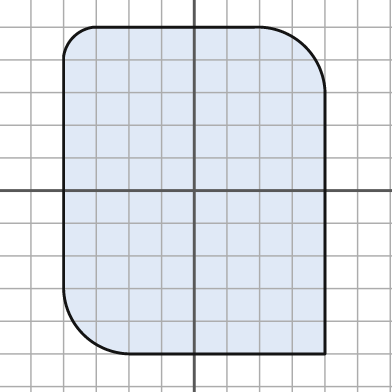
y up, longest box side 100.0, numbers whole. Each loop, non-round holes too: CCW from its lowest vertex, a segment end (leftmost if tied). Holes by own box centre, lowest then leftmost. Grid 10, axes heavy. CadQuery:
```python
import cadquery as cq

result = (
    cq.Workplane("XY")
    .moveTo(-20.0, -50.0)
    .lineTo(40.0, -50.0)
    .lineTo(40.0, 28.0)
    .threePointArc((34.0, 44.0), (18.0, 50.0))
    .lineTo(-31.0, 50.0)
    .threePointArc((-37.0, 47.0), (-40.0, 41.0))
    .lineTo(-40.0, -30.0)
    .threePointArc((-34.0, -44.0), (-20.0, -50.0))
    .close()
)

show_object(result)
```